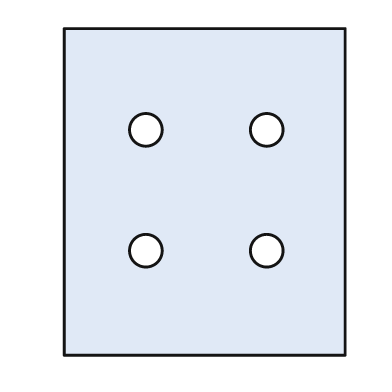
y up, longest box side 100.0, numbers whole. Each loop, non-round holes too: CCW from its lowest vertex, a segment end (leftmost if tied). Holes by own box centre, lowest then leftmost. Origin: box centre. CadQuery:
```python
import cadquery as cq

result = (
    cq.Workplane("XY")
    .moveTo(-43.0, -50.0)
    .lineTo(43.0, -50.0)
    .lineTo(43.0, 50.0)
    .lineTo(-43.0, 50.0)
    .close()
    .moveTo(-18.0, -18.0)
    .circle(5.0)
    .moveTo(19.0, -18.0)
    .circle(5.0)
    .moveTo(-18.0, 19.0)
    .circle(5.0)
    .moveTo(19.0, 19.0)
    .circle(5.0)
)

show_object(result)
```